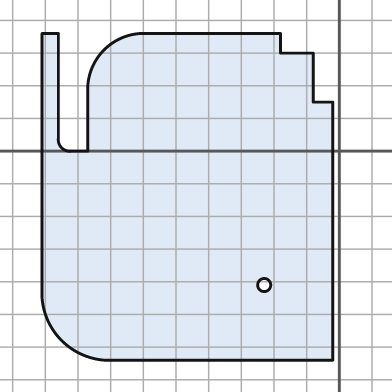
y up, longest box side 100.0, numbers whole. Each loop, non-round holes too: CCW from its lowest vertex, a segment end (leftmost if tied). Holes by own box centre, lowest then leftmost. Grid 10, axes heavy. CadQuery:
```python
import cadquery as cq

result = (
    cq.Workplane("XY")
    .moveTo(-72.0, -64.0)
    .lineTo(-2.0, -64.0)
    .lineTo(-2.0, 15.0)
    .lineTo(-8.0, 15.0)
    .lineTo(-8.0, 30.0)
    .lineTo(-18.0, 30.0)
    .lineTo(-18.0, 36.0)
    .lineTo(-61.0, 36.0)
    .threePointArc((-72.0, 31.0), (-77.0, 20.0))
    .lineTo(-77.0, 0.0)
    .lineTo(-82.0, 0.0)
    .threePointArc((-85.0, 1.0), (-86.0, 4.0))
    .lineTo(-86.0, 36.0)
    .lineTo(-91.0, 36.0)
    .lineTo(-91.0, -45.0)
    .threePointArc((-85.0, -58.0), (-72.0, -64.0))
    .close()
    .moveTo(-23.0, -41.0)
    .circle(2.0)
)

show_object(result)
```